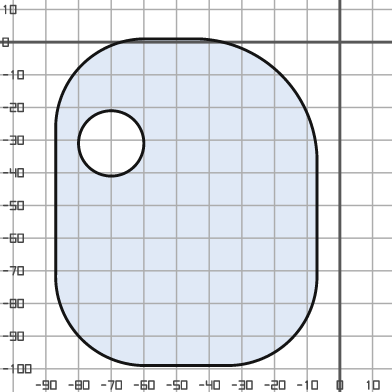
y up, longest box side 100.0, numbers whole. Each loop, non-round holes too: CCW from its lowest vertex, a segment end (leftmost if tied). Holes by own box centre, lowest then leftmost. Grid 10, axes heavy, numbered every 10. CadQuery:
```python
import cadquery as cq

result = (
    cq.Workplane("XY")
    .moveTo(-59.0, -99.0)
    .lineTo(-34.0, -99.0)
    .threePointArc((-15.0, -91.0), (-7.0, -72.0))
    .lineTo(-7.0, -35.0)
    .threePointArc((-18.0, -10.0), (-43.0, 1.0))
    .lineTo(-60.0, 1.0)
    .threePointArc((-79.0, -7.0), (-87.0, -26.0))
    .lineTo(-87.0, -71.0)
    .threePointArc((-79.0, -91.0), (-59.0, -99.0))
    .close()
    .moveTo(-70.0, -31.0)
    .circle(10.0)
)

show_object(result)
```